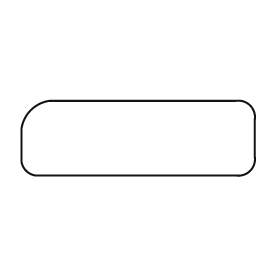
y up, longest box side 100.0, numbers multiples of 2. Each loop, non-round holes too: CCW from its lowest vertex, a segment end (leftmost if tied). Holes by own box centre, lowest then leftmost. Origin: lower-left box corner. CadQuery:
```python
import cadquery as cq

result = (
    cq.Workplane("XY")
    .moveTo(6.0, 0.0)
    .lineTo(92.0, 0.0)
    .threePointArc((98.0, 2.0), (100.0, 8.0))
    .lineTo(100.0, 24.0)
    .threePointArc((98.0, 30.0), (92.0, 32.0))
    .lineTo(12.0, 32.0)
    .threePointArc((4.0, 28.0), (0.0, 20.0))
    .lineTo(0.0, 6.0)
    .threePointArc((2.0, 2.0), (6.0, 0.0))
    .close()
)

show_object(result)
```